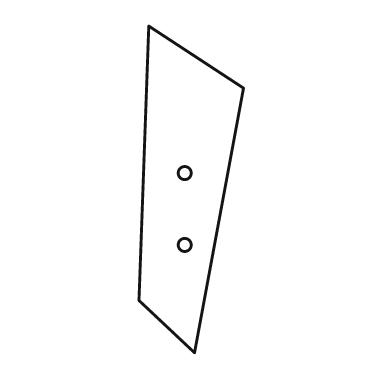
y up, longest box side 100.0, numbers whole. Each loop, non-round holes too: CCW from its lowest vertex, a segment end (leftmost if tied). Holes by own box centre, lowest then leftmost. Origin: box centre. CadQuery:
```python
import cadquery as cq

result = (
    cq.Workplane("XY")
    .moveTo(1.0, -50.0)
    .lineTo(16.0, 31.0)
    .lineTo(-13.0, 50.0)
    .lineTo(-16.0, -34.0)
    .close()
    .moveTo(-2.0, -17.0)
    .circle(2.0)
    .moveTo(-2.0, 5.0)
    .circle(2.0)
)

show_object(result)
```